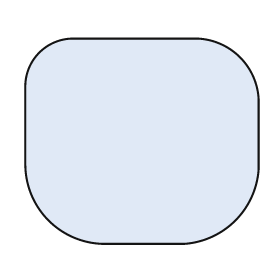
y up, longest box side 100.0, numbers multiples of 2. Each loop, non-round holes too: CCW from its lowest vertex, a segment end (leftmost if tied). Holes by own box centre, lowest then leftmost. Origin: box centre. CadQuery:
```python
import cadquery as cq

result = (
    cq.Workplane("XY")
    .moveTo(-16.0, -44.0)
    .lineTo(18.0, -44.0)
    .threePointArc((40.0, -34.0), (50.0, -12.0))
    .lineTo(50.0, 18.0)
    .threePointArc((42.0, 36.0), (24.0, 44.0))
    .lineTo(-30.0, 44.0)
    .threePointArc((-44.0, 38.0), (-50.0, 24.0))
    .lineTo(-50.0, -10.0)
    .threePointArc((-40.0, -34.0), (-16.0, -44.0))
    .close()
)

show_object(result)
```